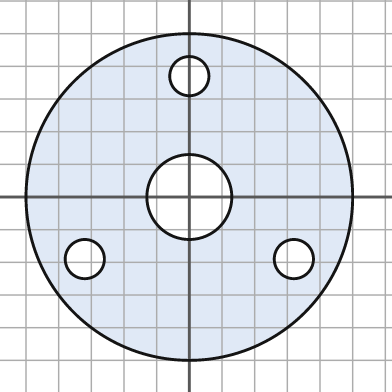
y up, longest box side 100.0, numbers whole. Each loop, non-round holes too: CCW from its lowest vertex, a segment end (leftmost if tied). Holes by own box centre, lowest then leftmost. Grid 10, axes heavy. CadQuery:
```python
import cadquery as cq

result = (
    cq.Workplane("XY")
    .moveTo(0.0, 0.0)
    .circle(50.0)
    .moveTo(-32.0, -19.0)
    .circle(6.0)
    .moveTo(32.0, -19.0)
    .circle(6.0)
    .moveTo(0.0, 0.0)
    .circle(13.0)
    .moveTo(0.0, 37.0)
    .circle(6.0)
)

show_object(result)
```